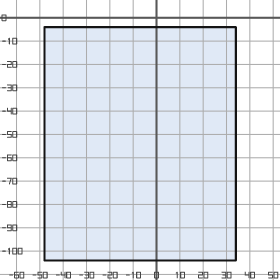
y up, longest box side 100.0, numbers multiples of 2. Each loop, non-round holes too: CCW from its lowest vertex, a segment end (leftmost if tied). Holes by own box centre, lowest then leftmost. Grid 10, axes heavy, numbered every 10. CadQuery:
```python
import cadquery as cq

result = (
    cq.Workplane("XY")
    .moveTo(-48.0, -104.0)
    .lineTo(34.0, -104.0)
    .lineTo(34.0, -4.0)
    .lineTo(-48.0, -4.0)
    .close()
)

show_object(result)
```